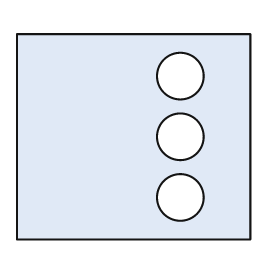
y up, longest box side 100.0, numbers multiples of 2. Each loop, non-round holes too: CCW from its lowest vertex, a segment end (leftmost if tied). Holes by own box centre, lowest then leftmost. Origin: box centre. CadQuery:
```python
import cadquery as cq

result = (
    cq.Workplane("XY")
    .moveTo(-50.0, -44.0)
    .lineTo(50.0, -44.0)
    .lineTo(50.0, 44.0)
    .lineTo(-50.0, 44.0)
    .close()
    .moveTo(20.0, -26.0)
    .circle(10.0)
    .moveTo(20.0, 0.0)
    .circle(10.0)
    .moveTo(20.0, 26.0)
    .circle(10.0)
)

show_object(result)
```